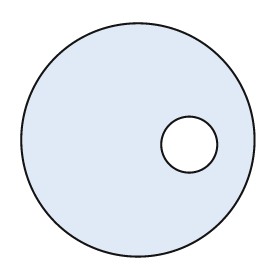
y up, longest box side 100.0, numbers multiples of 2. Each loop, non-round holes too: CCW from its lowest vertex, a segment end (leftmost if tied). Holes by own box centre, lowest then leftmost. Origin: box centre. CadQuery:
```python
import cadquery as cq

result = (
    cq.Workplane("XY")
    .moveTo(0.0, 0.0)
    .circle(50.0)
    .moveTo(22.0, -2.0)
    .circle(12.0)
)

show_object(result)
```